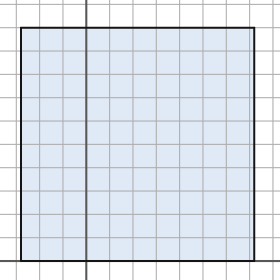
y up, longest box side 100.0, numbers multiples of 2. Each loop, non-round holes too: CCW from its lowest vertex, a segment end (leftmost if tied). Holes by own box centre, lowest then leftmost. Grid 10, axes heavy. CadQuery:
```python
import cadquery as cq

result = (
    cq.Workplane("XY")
    .moveTo(-28.0, 0.0)
    .lineTo(72.0, 0.0)
    .lineTo(72.0, 100.0)
    .lineTo(-28.0, 100.0)
    .close()
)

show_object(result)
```